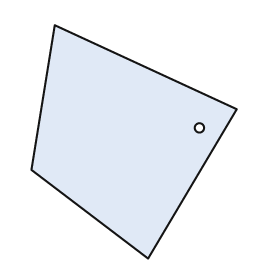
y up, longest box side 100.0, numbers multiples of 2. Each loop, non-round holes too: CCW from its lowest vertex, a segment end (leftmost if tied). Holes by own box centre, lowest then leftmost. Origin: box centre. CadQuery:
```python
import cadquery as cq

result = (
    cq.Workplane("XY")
    .moveTo(6.0, -50.0)
    .lineTo(44.0, 14.0)
    .lineTo(-34.0, 50.0)
    .lineTo(-44.0, -12.0)
    .close()
    .moveTo(28.0, 6.0)
    .circle(2.0)
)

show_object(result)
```